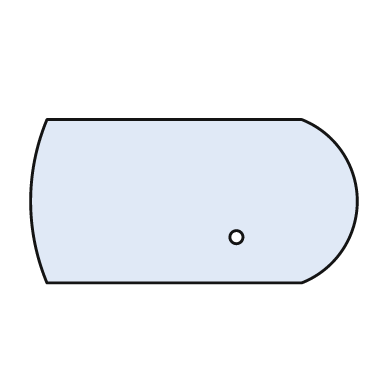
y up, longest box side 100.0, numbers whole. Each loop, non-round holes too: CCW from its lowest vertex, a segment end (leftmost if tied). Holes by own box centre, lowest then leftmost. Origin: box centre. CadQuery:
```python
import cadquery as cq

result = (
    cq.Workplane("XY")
    .moveTo(-45.0, -25.0)
    .lineTo(33.0, -25.0)
    .threePointArc((50.0, 0.0), (33.0, 25.0))
    .lineTo(-45.0, 25.0)
    .threePointArc((-50.0, 0.0), (-45.0, -25.0))
    .close()
    .moveTo(13.0, -11.0)
    .circle(2.0)
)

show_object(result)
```